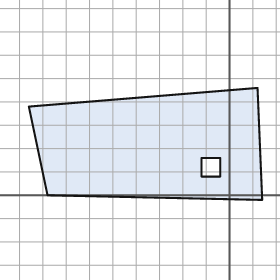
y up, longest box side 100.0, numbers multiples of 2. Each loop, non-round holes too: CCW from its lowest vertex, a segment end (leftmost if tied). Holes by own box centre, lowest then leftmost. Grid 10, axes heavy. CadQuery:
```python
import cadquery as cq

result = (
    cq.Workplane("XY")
    .moveTo(14.0, -2.0)
    .lineTo(12.0, 46.0)
    .lineTo(-86.0, 38.0)
    .lineTo(-78.0, 0.0)
    .close()
    .moveTo(-12.0, 8.0)
    .lineTo(-4.0, 8.0)
    .lineTo(-4.0, 16.0)
    .lineTo(-12.0, 16.0)
    .close()
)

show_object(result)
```